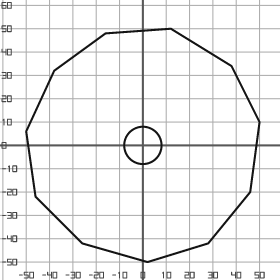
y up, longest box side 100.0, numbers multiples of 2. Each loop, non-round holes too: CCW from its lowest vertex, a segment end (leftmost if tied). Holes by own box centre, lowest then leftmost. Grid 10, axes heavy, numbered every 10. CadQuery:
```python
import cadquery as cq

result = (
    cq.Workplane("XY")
    .moveTo(2.0, -50.0)
    .lineTo(28.0, -42.0)
    .lineTo(46.0, -20.0)
    .lineTo(50.0, 10.0)
    .lineTo(38.0, 34.0)
    .lineTo(12.0, 50.0)
    .lineTo(-16.0, 48.0)
    .lineTo(-38.0, 32.0)
    .lineTo(-50.0, 6.0)
    .lineTo(-46.0, -22.0)
    .lineTo(-26.0, -42.0)
    .close()
    .moveTo(0.0, 0.0)
    .circle(8.0)
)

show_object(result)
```